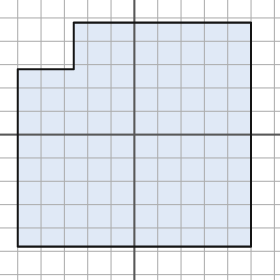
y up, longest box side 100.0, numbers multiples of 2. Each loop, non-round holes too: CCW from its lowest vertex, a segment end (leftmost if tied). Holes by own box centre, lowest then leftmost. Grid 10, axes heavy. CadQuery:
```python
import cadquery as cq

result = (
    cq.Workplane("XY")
    .moveTo(-50.0, -48.0)
    .lineTo(50.0, -48.0)
    .lineTo(50.0, 48.0)
    .lineTo(-26.0, 48.0)
    .lineTo(-26.0, 28.0)
    .lineTo(-50.0, 28.0)
    .close()
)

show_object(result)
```